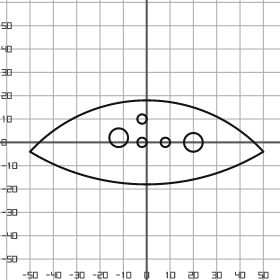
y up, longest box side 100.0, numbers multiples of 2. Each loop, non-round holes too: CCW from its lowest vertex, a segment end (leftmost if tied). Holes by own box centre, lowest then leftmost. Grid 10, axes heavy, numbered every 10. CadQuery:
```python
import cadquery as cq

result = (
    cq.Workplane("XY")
    .moveTo(-50.0, -4.0)
    .threePointArc((0.0, -18.0), (50.0, -4.0))
    .threePointArc((0.0, 18.0), (-50.0, -4.0))
    .close()
    .moveTo(-2.0, 0.0)
    .circle(2.0)
    .moveTo(8.0, 0.0)
    .circle(2.0)
    .moveTo(20.0, 0.0)
    .circle(4.0)
    .moveTo(-12.0, 2.0)
    .circle(4.0)
    .moveTo(-2.0, 10.0)
    .circle(2.0)
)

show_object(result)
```